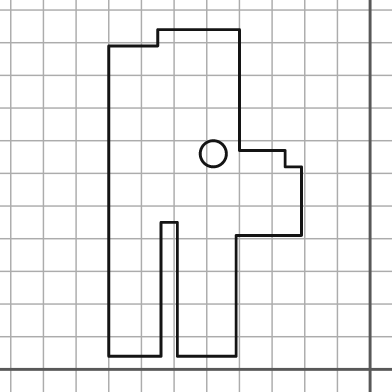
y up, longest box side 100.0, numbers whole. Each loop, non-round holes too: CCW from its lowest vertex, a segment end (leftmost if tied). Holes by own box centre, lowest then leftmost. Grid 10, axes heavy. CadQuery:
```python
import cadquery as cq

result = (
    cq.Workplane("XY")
    .moveTo(-80.0, 4.0)
    .lineTo(-64.0, 4.0)
    .lineTo(-64.0, 45.0)
    .lineTo(-59.0, 45.0)
    .lineTo(-59.0, 4.0)
    .lineTo(-41.0, 4.0)
    .lineTo(-41.0, 41.0)
    .lineTo(-21.0, 41.0)
    .lineTo(-21.0, 62.0)
    .lineTo(-26.0, 62.0)
    .lineTo(-26.0, 67.0)
    .lineTo(-40.0, 67.0)
    .lineTo(-40.0, 104.0)
    .lineTo(-65.0, 104.0)
    .lineTo(-65.0, 99.0)
    .lineTo(-80.0, 99.0)
    .close()
    .moveTo(-48.0, 66.0)
    .circle(4.0)
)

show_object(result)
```